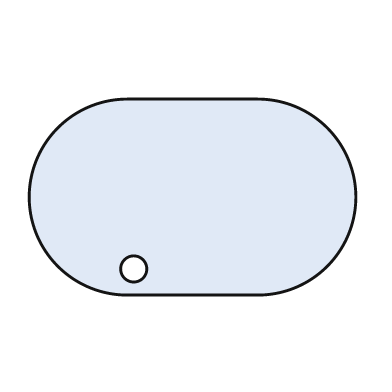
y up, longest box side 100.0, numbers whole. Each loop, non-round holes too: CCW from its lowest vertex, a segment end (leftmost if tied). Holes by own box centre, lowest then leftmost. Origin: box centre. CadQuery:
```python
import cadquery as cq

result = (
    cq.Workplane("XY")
    .moveTo(-20.0, -30.0)
    .lineTo(20.0, -30.0)
    .threePointArc((50.0, 0.0), (20.0, 30.0))
    .lineTo(-20.0, 30.0)
    .threePointArc((-50.0, 0.0), (-20.0, -30.0))
    .close()
    .moveTo(-18.0, -22.0)
    .circle(4.0)
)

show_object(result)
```